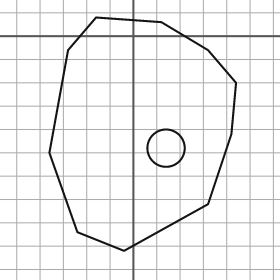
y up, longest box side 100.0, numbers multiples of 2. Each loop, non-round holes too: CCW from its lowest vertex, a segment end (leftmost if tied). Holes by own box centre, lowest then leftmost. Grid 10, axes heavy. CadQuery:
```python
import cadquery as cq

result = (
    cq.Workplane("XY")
    .moveTo(-4.0, -92.0)
    .lineTo(32.0, -72.0)
    .lineTo(42.0, -42.0)
    .lineTo(44.0, -20.0)
    .lineTo(32.0, -6.0)
    .lineTo(12.0, 6.0)
    .lineTo(-16.0, 8.0)
    .lineTo(-28.0, -6.0)
    .lineTo(-36.0, -50.0)
    .lineTo(-24.0, -84.0)
    .close()
    .moveTo(14.0, -48.0)
    .circle(8.0)
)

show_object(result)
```